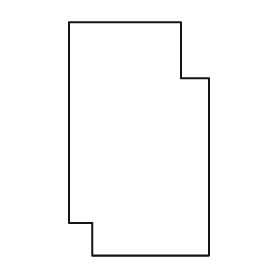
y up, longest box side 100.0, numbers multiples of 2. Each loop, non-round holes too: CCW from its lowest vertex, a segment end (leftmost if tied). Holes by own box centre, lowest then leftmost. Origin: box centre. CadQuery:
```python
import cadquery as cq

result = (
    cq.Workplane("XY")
    .moveTo(-20.0, -50.0)
    .lineTo(30.0, -50.0)
    .lineTo(30.0, 26.0)
    .lineTo(18.0, 26.0)
    .lineTo(18.0, 50.0)
    .lineTo(-30.0, 50.0)
    .lineTo(-30.0, -36.0)
    .lineTo(-20.0, -36.0)
    .close()
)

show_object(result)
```